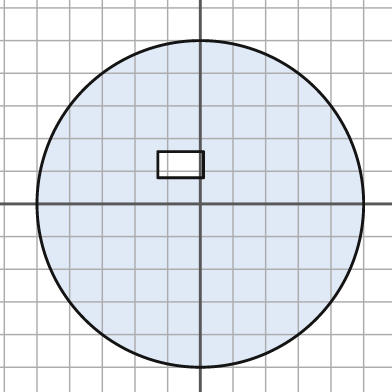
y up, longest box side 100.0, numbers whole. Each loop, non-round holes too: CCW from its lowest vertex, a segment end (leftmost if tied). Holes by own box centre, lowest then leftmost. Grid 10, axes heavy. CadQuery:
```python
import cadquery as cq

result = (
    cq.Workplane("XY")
    .moveTo(0.0, 0.0)
    .circle(50.0)
    .moveTo(-13.0, 8.0)
    .lineTo(1.0, 8.0)
    .lineTo(1.0, 16.0)
    .lineTo(-13.0, 16.0)
    .close()
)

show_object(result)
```